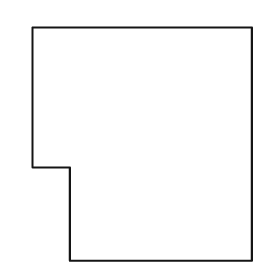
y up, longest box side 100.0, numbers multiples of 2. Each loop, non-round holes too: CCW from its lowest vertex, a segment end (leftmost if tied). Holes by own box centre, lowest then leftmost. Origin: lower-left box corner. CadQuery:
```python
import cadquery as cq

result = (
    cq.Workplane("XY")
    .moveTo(16.0, 0.0)
    .lineTo(94.0, 0.0)
    .lineTo(94.0, 100.0)
    .lineTo(0.0, 100.0)
    .lineTo(0.0, 40.0)
    .lineTo(16.0, 40.0)
    .close()
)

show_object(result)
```